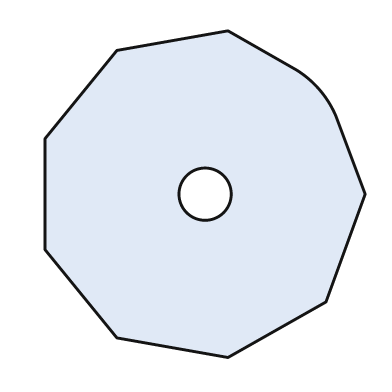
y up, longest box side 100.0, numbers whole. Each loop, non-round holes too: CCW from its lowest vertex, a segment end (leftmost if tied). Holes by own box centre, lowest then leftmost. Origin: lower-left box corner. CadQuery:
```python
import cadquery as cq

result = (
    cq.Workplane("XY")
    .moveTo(56.0, 0.0)
    .lineTo(86.0, 17.0)
    .lineTo(98.0, 50.0)
    .lineTo(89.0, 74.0)
    .threePointArc((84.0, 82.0), (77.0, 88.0))
    .lineTo(56.0, 100.0)
    .lineTo(22.0, 94.0)
    .lineTo(0.0, 67.0)
    .lineTo(0.0, 33.0)
    .lineTo(22.0, 6.0)
    .close()
    .moveTo(49.0, 50.0)
    .circle(8.0)
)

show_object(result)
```